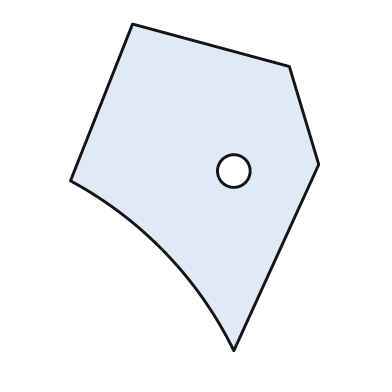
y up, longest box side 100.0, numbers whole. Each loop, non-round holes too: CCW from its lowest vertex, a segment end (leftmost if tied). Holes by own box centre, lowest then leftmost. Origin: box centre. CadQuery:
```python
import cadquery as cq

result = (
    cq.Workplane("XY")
    .moveTo(12.0, -50.0)
    .lineTo(38.0, 7.0)
    .lineTo(29.0, 37.0)
    .lineTo(-19.0, 50.0)
    .lineTo(-38.0, 2.0)
    .threePointArc((-9.0, -20.0), (12.0, -50.0))
    .close()
    .moveTo(12.0, 5.0)
    .circle(5.0)
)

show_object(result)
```